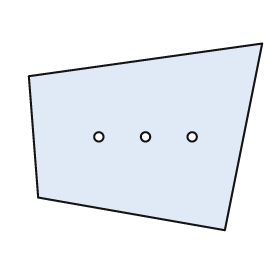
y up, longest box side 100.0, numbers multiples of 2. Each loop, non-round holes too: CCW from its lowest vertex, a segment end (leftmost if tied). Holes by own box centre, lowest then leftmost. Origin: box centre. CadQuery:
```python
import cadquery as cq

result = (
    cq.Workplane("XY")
    .moveTo(34.0, -40.0)
    .lineTo(50.0, 40.0)
    .lineTo(-50.0, 26.0)
    .lineTo(-46.0, -26.0)
    .close()
    .moveTo(-20.0, 0.0)
    .circle(2.0)
    .moveTo(0.0, 0.0)
    .circle(2.0)
    .moveTo(20.0, 0.0)
    .circle(2.0)
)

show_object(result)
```